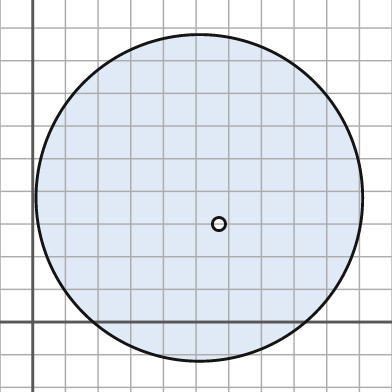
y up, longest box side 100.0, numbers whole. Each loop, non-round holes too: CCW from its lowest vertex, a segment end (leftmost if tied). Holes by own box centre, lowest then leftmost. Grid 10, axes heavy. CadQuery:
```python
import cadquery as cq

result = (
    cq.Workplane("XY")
    .moveTo(51.0, 38.0)
    .circle(50.0)
    .moveTo(57.0, 30.0)
    .circle(2.0)
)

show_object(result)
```